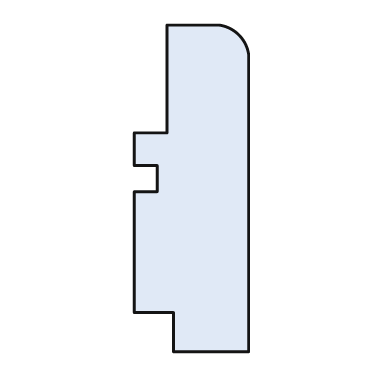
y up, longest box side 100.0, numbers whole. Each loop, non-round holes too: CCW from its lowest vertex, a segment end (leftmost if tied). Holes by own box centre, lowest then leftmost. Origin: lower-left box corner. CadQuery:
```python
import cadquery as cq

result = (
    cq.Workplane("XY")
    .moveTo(12.0, 0.0)
    .lineTo(35.0, 0.0)
    .lineTo(35.0, 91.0)
    .threePointArc((32.0, 97.0), (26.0, 100.0))
    .lineTo(10.0, 100.0)
    .lineTo(10.0, 67.0)
    .lineTo(0.0, 67.0)
    .lineTo(0.0, 57.0)
    .lineTo(7.0, 57.0)
    .lineTo(7.0, 49.0)
    .lineTo(0.0, 49.0)
    .lineTo(0.0, 12.0)
    .lineTo(12.0, 12.0)
    .close()
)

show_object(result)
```